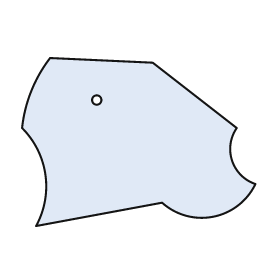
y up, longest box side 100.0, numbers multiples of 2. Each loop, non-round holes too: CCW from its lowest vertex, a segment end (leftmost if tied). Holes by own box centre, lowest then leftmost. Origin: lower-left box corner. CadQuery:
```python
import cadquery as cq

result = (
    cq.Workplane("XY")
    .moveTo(6.0, 0.0)
    .lineTo(60.0, 10.0)
    .threePointArc((82.0, 4.0), (100.0, 18.0))
    .threePointArc((90.0, 28.0), (92.0, 42.0))
    .lineTo(56.0, 70.0)
    .lineTo(12.0, 72.0)
    .threePointArc((4.0, 58.0), (0.0, 42.0))
    .threePointArc((10.0, 22.0), (6.0, 0.0))
    .close()
    .moveTo(32.0, 54.0)
    .circle(2.0)
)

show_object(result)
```